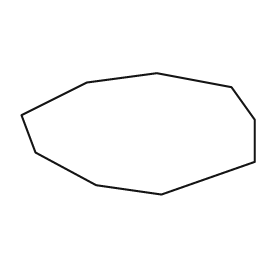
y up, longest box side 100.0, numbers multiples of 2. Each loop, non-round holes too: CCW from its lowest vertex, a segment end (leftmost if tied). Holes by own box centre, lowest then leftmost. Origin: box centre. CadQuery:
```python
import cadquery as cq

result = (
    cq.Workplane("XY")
    .moveTo(10.0, -26.0)
    .lineTo(50.0, -12.0)
    .lineTo(50.0, 6.0)
    .lineTo(40.0, 20.0)
    .lineTo(8.0, 26.0)
    .lineTo(-22.0, 22.0)
    .lineTo(-50.0, 8.0)
    .lineTo(-44.0, -8.0)
    .lineTo(-18.0, -22.0)
    .close()
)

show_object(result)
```